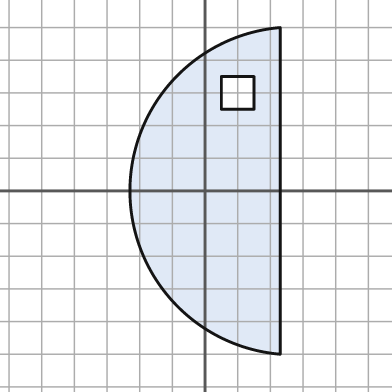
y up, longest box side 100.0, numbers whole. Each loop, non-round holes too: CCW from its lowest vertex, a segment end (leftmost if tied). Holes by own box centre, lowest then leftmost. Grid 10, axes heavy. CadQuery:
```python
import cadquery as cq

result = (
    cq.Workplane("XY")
    .moveTo(23.0, -50.0)
    .lineTo(23.0, 50.0)
    .threePointArc((-23.0, 0.0), (23.0, -50.0))
    .close()
    .moveTo(5.0, 25.0)
    .lineTo(15.0, 25.0)
    .lineTo(15.0, 35.0)
    .lineTo(5.0, 35.0)
    .close()
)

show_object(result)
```